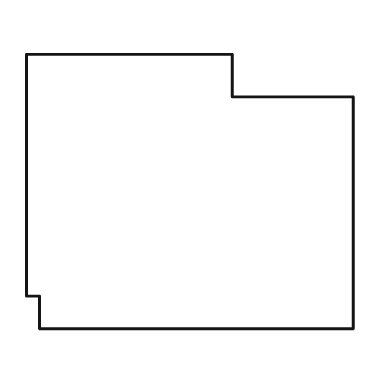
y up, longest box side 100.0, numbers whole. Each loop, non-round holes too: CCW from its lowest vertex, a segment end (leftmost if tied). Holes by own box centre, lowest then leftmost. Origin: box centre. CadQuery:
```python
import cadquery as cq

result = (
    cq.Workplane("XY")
    .moveTo(-46.0, -42.0)
    .lineTo(50.0, -42.0)
    .lineTo(50.0, 29.0)
    .lineTo(13.0, 29.0)
    .lineTo(13.0, 42.0)
    .lineTo(-50.0, 42.0)
    .lineTo(-50.0, -32.0)
    .lineTo(-46.0, -32.0)
    .close()
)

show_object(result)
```